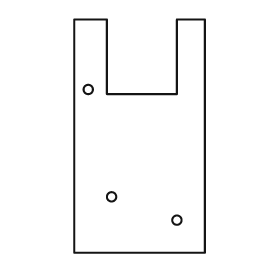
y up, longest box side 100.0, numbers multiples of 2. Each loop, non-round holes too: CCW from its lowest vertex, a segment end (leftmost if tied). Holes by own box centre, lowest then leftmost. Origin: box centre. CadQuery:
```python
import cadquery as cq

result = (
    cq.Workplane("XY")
    .moveTo(-28.0, -50.0)
    .lineTo(28.0, -50.0)
    .lineTo(28.0, 50.0)
    .lineTo(16.0, 50.0)
    .lineTo(16.0, 18.0)
    .lineTo(-14.0, 18.0)
    .lineTo(-14.0, 50.0)
    .lineTo(-28.0, 50.0)
    .close()
    .moveTo(16.0, -36.0)
    .circle(2.0)
    .moveTo(-12.0, -26.0)
    .circle(2.0)
    .moveTo(-22.0, 20.0)
    .circle(2.0)
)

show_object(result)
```